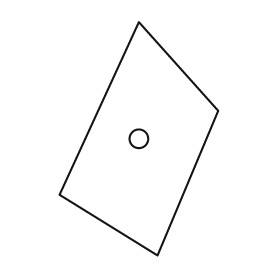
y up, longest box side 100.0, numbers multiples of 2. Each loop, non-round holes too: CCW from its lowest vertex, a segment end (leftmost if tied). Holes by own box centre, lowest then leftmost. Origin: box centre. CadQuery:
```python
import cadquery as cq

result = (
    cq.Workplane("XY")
    .moveTo(8.0, -50.0)
    .lineTo(34.0, 12.0)
    .lineTo(0.0, 50.0)
    .lineTo(-34.0, -24.0)
    .close()
    .moveTo(0.0, 0.0)
    .circle(4.0)
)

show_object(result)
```